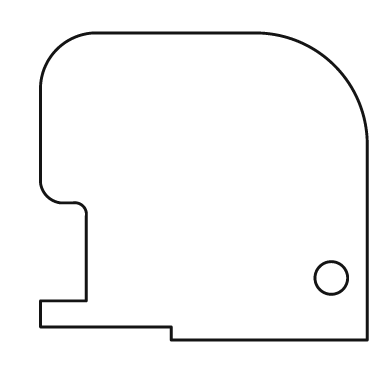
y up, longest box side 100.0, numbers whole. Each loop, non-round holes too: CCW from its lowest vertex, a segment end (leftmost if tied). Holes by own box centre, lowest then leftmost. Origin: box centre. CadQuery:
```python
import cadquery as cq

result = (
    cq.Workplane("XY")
    .moveTo(-10.0, -47.0)
    .lineTo(50.0, -47.0)
    .lineTo(50.0, 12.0)
    .threePointArc((40.0, 37.0), (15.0, 47.0))
    .lineTo(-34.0, 47.0)
    .threePointArc((-45.0, 42.0), (-50.0, 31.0))
    .lineTo(-50.0, 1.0)
    .threePointArc((-48.0, -3.0), (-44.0, -5.0))
    .lineTo(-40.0, -5.0)
    .threePointArc((-37.0, -6.0), (-36.0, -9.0))
    .lineTo(-36.0, -35.0)
    .lineTo(-50.0, -35.0)
    .lineTo(-50.0, -43.0)
    .lineTo(-10.0, -43.0)
    .close()
    .moveTo(39.0, -28.0)
    .circle(5.0)
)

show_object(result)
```